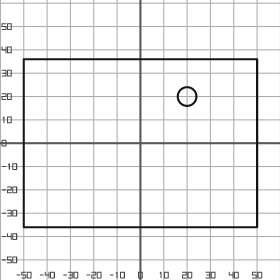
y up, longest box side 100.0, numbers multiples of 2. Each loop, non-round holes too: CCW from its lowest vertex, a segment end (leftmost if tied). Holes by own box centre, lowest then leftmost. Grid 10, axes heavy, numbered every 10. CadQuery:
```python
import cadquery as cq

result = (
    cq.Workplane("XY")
    .moveTo(-50.0, -36.0)
    .lineTo(50.0, -36.0)
    .lineTo(50.0, 36.0)
    .lineTo(-50.0, 36.0)
    .close()
    .moveTo(20.0, 20.0)
    .circle(4.0)
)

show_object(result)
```